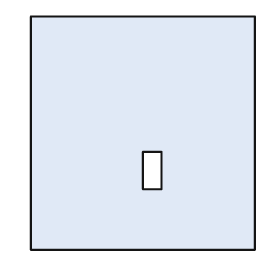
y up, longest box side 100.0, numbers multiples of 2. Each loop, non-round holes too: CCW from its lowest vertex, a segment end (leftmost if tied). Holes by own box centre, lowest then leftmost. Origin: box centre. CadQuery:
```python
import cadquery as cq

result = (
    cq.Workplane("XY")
    .moveTo(-48.0, -50.0)
    .lineTo(48.0, -50.0)
    .lineTo(48.0, 50.0)
    .lineTo(-48.0, 50.0)
    .close()
    .moveTo(0.0, -24.0)
    .lineTo(8.0, -24.0)
    .lineTo(8.0, -8.0)
    .lineTo(0.0, -8.0)
    .close()
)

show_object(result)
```